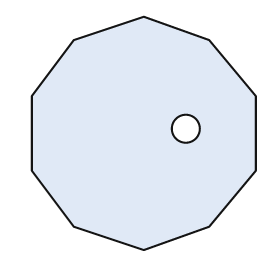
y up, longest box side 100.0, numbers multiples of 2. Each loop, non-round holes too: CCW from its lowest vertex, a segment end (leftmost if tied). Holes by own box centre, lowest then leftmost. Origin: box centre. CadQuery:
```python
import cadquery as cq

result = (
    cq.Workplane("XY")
    .moveTo(0.0, -50.0)
    .lineTo(28.0, -40.0)
    .lineTo(48.0, -16.0)
    .lineTo(48.0, 16.0)
    .lineTo(28.0, 40.0)
    .lineTo(0.0, 50.0)
    .lineTo(-30.0, 40.0)
    .lineTo(-48.0, 16.0)
    .lineTo(-48.0, -16.0)
    .lineTo(-30.0, -40.0)
    .close()
    .moveTo(18.0, 2.0)
    .circle(6.0)
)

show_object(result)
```